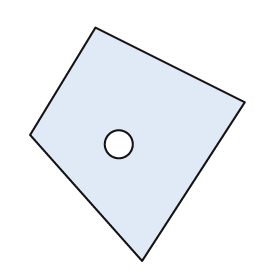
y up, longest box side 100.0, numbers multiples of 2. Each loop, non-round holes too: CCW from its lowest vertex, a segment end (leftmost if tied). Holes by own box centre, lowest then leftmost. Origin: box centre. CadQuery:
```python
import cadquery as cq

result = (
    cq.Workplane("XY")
    .moveTo(2.0, -50.0)
    .lineTo(46.0, 18.0)
    .lineTo(-18.0, 50.0)
    .lineTo(-46.0, 4.0)
    .close()
    .moveTo(-8.0, 0.0)
    .circle(6.0)
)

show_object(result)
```